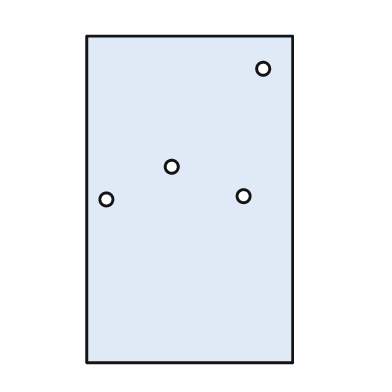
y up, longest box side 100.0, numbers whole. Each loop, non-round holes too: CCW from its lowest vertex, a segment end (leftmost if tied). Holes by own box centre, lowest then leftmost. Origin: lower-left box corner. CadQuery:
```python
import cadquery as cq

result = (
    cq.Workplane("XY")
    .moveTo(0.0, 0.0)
    .lineTo(63.0, 0.0)
    .lineTo(63.0, 100.0)
    .lineTo(0.0, 100.0)
    .close()
    .moveTo(6.0, 50.0)
    .circle(2.0)
    .moveTo(48.0, 51.0)
    .circle(2.0)
    .moveTo(26.0, 60.0)
    .circle(2.0)
    .moveTo(54.0, 90.0)
    .circle(2.0)
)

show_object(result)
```